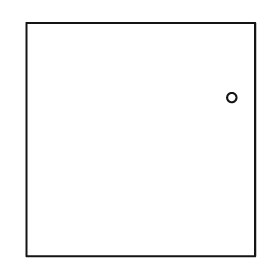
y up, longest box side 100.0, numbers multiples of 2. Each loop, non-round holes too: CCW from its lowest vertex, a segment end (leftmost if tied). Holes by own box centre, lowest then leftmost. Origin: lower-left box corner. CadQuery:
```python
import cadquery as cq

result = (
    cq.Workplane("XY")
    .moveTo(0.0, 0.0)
    .lineTo(98.0, 0.0)
    .lineTo(98.0, 100.0)
    .lineTo(0.0, 100.0)
    .close()
    .moveTo(88.0, 68.0)
    .circle(2.0)
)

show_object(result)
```